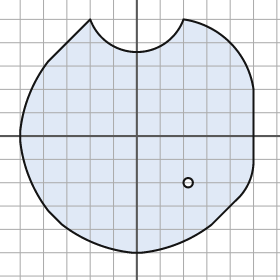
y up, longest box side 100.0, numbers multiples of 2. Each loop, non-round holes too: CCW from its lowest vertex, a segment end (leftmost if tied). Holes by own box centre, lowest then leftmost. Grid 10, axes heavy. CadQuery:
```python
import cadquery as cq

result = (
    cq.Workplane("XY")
    .moveTo(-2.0, -50.0)
    .lineTo(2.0, -50.0)
    .threePointArc((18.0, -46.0), (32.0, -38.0))
    .lineTo(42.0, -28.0)
    .threePointArc((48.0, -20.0), (50.0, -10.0))
    .lineTo(50.0, 20.0)
    .threePointArc((40.0, 40.0), (20.0, 50.0))
    .threePointArc((0.0, 36.0), (-20.0, 50.0))
    .lineTo(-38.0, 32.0)
    .threePointArc((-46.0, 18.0), (-50.0, 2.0))
    .lineTo(-50.0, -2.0)
    .threePointArc((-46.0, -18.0), (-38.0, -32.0))
    .lineTo(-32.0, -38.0)
    .threePointArc((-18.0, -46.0), (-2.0, -50.0))
    .close()
    .moveTo(22.0, -20.0)
    .circle(2.0)
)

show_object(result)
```